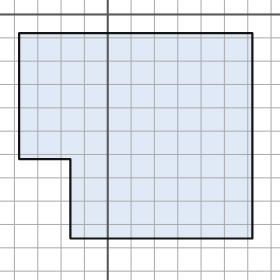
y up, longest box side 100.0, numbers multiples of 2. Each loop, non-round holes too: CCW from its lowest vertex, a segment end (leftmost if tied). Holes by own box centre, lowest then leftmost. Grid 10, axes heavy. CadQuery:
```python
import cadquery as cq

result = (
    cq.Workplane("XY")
    .moveTo(-16.0, -96.0)
    .lineTo(62.0, -96.0)
    .lineTo(62.0, -8.0)
    .lineTo(-38.0, -8.0)
    .lineTo(-38.0, -62.0)
    .lineTo(-16.0, -62.0)
    .close()
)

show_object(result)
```